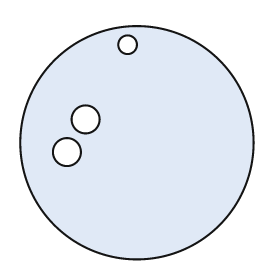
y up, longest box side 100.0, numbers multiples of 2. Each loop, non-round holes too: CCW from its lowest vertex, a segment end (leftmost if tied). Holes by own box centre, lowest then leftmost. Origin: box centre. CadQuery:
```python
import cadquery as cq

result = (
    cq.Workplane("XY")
    .moveTo(0.0, 0.0)
    .circle(50.0)
    .moveTo(-30.0, -4.0)
    .circle(6.0)
    .moveTo(-22.0, 10.0)
    .circle(6.0)
    .moveTo(-4.0, 42.0)
    .circle(4.0)
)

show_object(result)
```